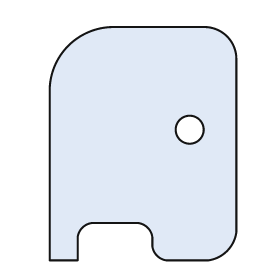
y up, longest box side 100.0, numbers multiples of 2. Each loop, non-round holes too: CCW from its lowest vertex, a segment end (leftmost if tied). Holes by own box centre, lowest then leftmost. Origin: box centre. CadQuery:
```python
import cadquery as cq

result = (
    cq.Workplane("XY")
    .moveTo(-40.0, -50.0)
    .lineTo(-28.0, -50.0)
    .lineTo(-28.0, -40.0)
    .threePointArc((-26.0, -36.0), (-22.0, -34.0))
    .lineTo(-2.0, -34.0)
    .threePointArc((2.0, -36.0), (4.0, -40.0))
    .lineTo(4.0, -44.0)
    .threePointArc((6.0, -48.0), (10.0, -50.0))
    .lineTo(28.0, -50.0)
    .threePointArc((36.0, -46.0), (40.0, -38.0))
    .lineTo(40.0, 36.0)
    .threePointArc((36.0, 46.0), (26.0, 50.0))
    .lineTo(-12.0, 50.0)
    .threePointArc((-32.0, 42.0), (-40.0, 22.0))
    .close()
    .moveTo(20.0, 6.0)
    .circle(6.0)
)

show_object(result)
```